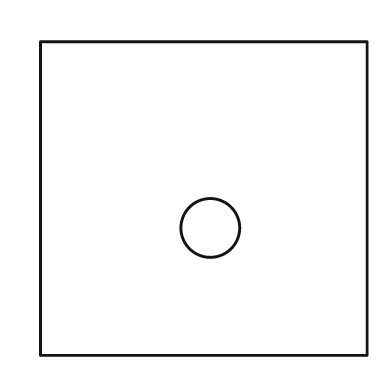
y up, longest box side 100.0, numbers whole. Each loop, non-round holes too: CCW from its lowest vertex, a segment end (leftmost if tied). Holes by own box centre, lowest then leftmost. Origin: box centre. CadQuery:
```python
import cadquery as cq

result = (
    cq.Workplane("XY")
    .moveTo(-50.0, -48.0)
    .lineTo(50.0, -48.0)
    .lineTo(50.0, 48.0)
    .lineTo(-50.0, 48.0)
    .close()
    .moveTo(2.0, -9.0)
    .circle(9.0)
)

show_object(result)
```